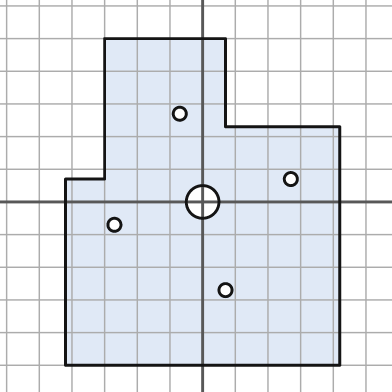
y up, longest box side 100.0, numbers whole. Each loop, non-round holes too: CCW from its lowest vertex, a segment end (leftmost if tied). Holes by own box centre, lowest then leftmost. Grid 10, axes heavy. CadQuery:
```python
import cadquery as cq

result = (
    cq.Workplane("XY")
    .moveTo(-42.0, -50.0)
    .lineTo(42.0, -50.0)
    .lineTo(42.0, 23.0)
    .lineTo(7.0, 23.0)
    .lineTo(7.0, 50.0)
    .lineTo(-30.0, 50.0)
    .lineTo(-30.0, 7.0)
    .lineTo(-42.0, 7.0)
    .close()
    .moveTo(7.0, -27.0)
    .circle(2.0)
    .moveTo(-27.0, -7.0)
    .circle(2.0)
    .moveTo(0.0, 0.0)
    .circle(5.0)
    .moveTo(27.0, 7.0)
    .circle(2.0)
    .moveTo(-7.0, 27.0)
    .circle(2.0)
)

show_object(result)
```